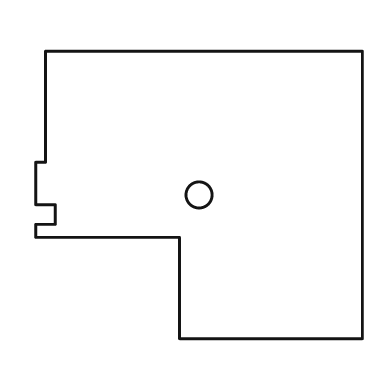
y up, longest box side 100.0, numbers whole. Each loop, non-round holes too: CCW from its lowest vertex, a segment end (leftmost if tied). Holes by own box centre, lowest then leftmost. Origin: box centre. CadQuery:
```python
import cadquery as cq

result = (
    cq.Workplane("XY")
    .moveTo(-6.0, -44.0)
    .lineTo(50.0, -44.0)
    .lineTo(50.0, 44.0)
    .lineTo(-47.0, 44.0)
    .lineTo(-47.0, 10.0)
    .lineTo(-50.0, 10.0)
    .lineTo(-50.0, -3.0)
    .lineTo(-44.0, -3.0)
    .lineTo(-44.0, -9.0)
    .lineTo(-50.0, -9.0)
    .lineTo(-50.0, -13.0)
    .lineTo(-6.0, -13.0)
    .close()
    .moveTo(0.0, 0.0)
    .circle(4.0)
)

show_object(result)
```